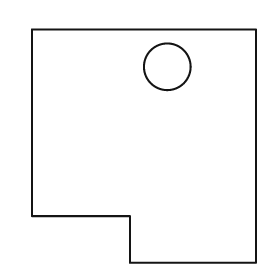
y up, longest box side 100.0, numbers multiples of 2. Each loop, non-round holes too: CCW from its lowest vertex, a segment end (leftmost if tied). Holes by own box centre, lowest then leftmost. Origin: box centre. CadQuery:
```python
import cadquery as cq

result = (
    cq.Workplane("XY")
    .moveTo(-6.0, -50.0)
    .lineTo(48.0, -50.0)
    .lineTo(48.0, 50.0)
    .lineTo(-48.0, 50.0)
    .lineTo(-48.0, -30.0)
    .lineTo(-6.0, -30.0)
    .close()
    .moveTo(10.0, 34.0)
    .circle(10.0)
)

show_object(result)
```